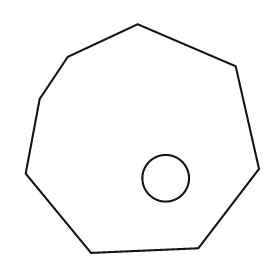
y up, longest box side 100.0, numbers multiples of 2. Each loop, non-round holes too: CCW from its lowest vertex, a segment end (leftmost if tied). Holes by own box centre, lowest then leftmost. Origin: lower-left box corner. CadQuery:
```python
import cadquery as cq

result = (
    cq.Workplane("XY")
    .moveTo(28.0, 0.0)
    .lineTo(74.0, 2.0)
    .lineTo(100.0, 36.0)
    .lineTo(90.0, 80.0)
    .lineTo(48.0, 98.0)
    .lineTo(18.0, 84.0)
    .lineTo(6.0, 66.0)
    .lineTo(0.0, 34.0)
    .close()
    .moveTo(60.0, 32.0)
    .circle(10.0)
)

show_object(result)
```